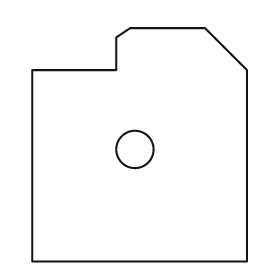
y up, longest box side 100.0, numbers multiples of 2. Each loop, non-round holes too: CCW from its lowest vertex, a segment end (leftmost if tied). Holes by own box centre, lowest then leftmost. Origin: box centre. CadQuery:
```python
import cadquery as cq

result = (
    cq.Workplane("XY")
    .moveTo(-46.0, -50.0)
    .lineTo(46.0, -50.0)
    .lineTo(46.0, 32.0)
    .lineTo(28.0, 50.0)
    .lineTo(-4.0, 50.0)
    .lineTo(-10.0, 46.0)
    .lineTo(-10.0, 32.0)
    .lineTo(-46.0, 32.0)
    .close()
    .moveTo(-2.0, -2.0)
    .circle(8.0)
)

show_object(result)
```